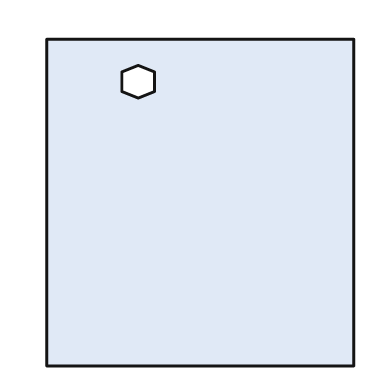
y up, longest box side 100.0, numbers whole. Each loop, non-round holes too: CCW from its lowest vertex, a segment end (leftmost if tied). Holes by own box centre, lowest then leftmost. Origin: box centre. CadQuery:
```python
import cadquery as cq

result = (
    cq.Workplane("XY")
    .moveTo(-47.0, -50.0)
    .lineTo(47.0, -50.0)
    .lineTo(47.0, 50.0)
    .lineTo(-47.0, 50.0)
    .close()
    .moveTo(-19.0, 32.0)
    .lineTo(-14.0, 34.0)
    .lineTo(-14.0, 40.0)
    .lineTo(-19.0, 42.0)
    .lineTo(-24.0, 40.0)
    .lineTo(-24.0, 34.0)
    .close()
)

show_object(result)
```